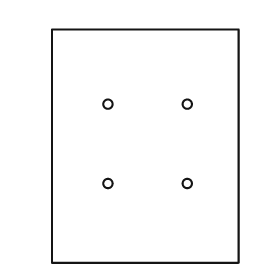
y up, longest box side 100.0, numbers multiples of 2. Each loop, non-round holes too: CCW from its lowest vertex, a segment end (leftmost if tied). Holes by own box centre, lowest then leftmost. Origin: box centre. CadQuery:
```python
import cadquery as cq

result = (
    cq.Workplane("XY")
    .moveTo(-40.0, -50.0)
    .lineTo(40.0, -50.0)
    .lineTo(40.0, 50.0)
    .lineTo(-40.0, 50.0)
    .close()
    .moveTo(-16.0, -16.0)
    .circle(2.0)
    .moveTo(18.0, -16.0)
    .circle(2.0)
    .moveTo(-16.0, 18.0)
    .circle(2.0)
    .moveTo(18.0, 18.0)
    .circle(2.0)
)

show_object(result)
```